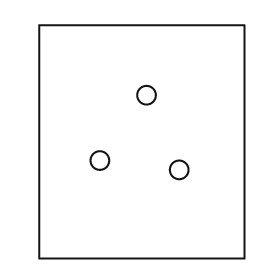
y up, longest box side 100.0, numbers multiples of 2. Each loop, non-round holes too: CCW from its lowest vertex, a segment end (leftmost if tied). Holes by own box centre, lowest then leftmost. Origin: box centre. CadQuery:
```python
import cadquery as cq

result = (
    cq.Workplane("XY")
    .moveTo(-44.0, -50.0)
    .lineTo(44.0, -50.0)
    .lineTo(44.0, 50.0)
    .lineTo(-44.0, 50.0)
    .close()
    .moveTo(16.0, -12.0)
    .circle(4.0)
    .moveTo(-18.0, -8.0)
    .circle(4.0)
    .moveTo(2.0, 20.0)
    .circle(4.0)
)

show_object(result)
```